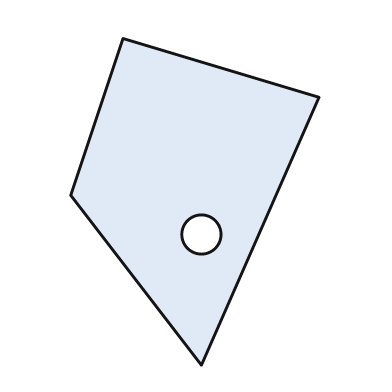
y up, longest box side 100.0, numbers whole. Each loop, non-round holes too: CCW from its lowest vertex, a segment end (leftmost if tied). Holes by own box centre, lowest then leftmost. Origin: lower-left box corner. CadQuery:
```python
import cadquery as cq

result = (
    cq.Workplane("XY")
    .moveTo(40.0, 0.0)
    .lineTo(76.0, 82.0)
    .lineTo(16.0, 100.0)
    .lineTo(0.0, 52.0)
    .close()
    .moveTo(40.0, 40.0)
    .circle(6.0)
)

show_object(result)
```